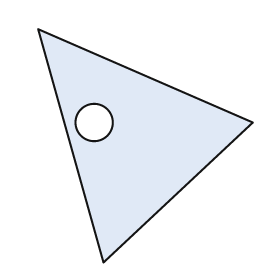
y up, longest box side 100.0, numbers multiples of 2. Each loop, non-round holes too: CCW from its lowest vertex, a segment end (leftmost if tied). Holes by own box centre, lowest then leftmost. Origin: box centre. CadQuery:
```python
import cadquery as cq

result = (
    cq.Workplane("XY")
    .moveTo(-18.0, -50.0)
    .lineTo(46.0, 10.0)
    .lineTo(-46.0, 50.0)
    .close()
    .moveTo(-22.0, 10.0)
    .circle(8.0)
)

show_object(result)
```